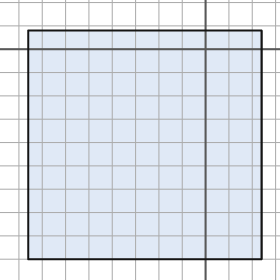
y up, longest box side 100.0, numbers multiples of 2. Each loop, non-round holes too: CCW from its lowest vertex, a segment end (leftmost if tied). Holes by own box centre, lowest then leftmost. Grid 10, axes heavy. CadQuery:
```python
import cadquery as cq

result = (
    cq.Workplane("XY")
    .moveTo(-76.0, -90.0)
    .lineTo(24.0, -90.0)
    .lineTo(24.0, 8.0)
    .lineTo(-76.0, 8.0)
    .close()
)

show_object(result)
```